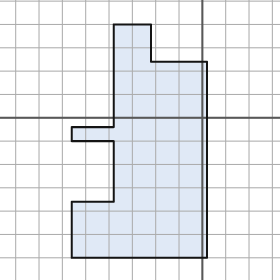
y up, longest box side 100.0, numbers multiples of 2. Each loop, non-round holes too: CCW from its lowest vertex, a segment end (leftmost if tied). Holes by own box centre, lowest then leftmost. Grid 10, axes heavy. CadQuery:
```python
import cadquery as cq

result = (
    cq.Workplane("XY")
    .moveTo(-56.0, -60.0)
    .lineTo(2.0, -60.0)
    .lineTo(2.0, 24.0)
    .lineTo(-22.0, 24.0)
    .lineTo(-22.0, 40.0)
    .lineTo(-38.0, 40.0)
    .lineTo(-38.0, -4.0)
    .lineTo(-56.0, -4.0)
    .lineTo(-56.0, -10.0)
    .lineTo(-38.0, -10.0)
    .lineTo(-38.0, -36.0)
    .lineTo(-56.0, -36.0)
    .close()
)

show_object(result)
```